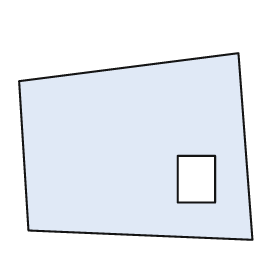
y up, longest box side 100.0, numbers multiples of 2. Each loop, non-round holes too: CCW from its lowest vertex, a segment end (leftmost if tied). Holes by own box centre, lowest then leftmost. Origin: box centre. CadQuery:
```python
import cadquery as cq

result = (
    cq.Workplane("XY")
    .moveTo(50.0, -40.0)
    .lineTo(44.0, 40.0)
    .lineTo(-50.0, 28.0)
    .lineTo(-46.0, -36.0)
    .close()
    .moveTo(18.0, -24.0)
    .lineTo(34.0, -24.0)
    .lineTo(34.0, -4.0)
    .lineTo(18.0, -4.0)
    .close()
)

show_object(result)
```